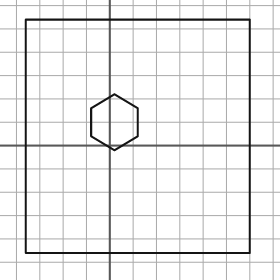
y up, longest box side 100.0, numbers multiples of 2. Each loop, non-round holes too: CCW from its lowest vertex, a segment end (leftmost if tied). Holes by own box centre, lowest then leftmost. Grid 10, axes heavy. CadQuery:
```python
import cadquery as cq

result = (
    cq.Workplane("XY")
    .moveTo(-36.0, -46.0)
    .lineTo(60.0, -46.0)
    .lineTo(60.0, 54.0)
    .lineTo(-36.0, 54.0)
    .close()
    .moveTo(2.0, -2.0)
    .lineTo(12.0, 4.0)
    .lineTo(12.0, 16.0)
    .lineTo(2.0, 22.0)
    .lineTo(-8.0, 16.0)
    .lineTo(-8.0, 4.0)
    .close()
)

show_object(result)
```